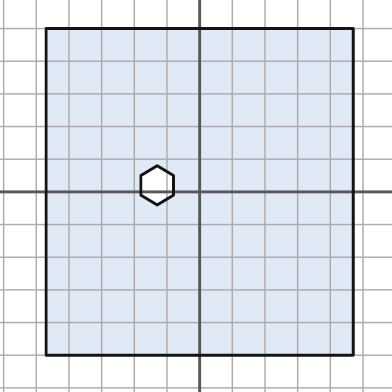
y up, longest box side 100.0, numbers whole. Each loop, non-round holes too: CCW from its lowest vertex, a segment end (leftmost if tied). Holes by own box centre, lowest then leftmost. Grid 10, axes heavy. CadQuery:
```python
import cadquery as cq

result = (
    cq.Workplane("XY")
    .moveTo(-47.0, -50.0)
    .lineTo(47.0, -50.0)
    .lineTo(47.0, 50.0)
    .lineTo(-47.0, 50.0)
    .close()
    .moveTo(-13.0, -4.0)
    .lineTo(-8.0, -1.0)
    .lineTo(-8.0, 5.0)
    .lineTo(-13.0, 8.0)
    .lineTo(-18.0, 5.0)
    .lineTo(-18.0, -1.0)
    .close()
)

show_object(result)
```